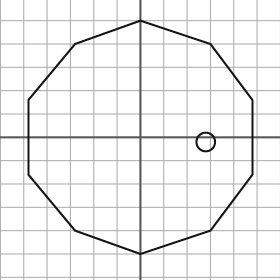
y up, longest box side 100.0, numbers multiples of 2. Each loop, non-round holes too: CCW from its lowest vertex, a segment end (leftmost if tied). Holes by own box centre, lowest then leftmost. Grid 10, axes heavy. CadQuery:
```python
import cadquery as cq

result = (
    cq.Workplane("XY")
    .moveTo(0.0, -50.0)
    .lineTo(30.0, -40.0)
    .lineTo(48.0, -16.0)
    .lineTo(48.0, 16.0)
    .lineTo(30.0, 40.0)
    .lineTo(0.0, 50.0)
    .lineTo(-28.0, 40.0)
    .lineTo(-48.0, 16.0)
    .lineTo(-48.0, -16.0)
    .lineTo(-28.0, -40.0)
    .close()
    .moveTo(28.0, -2.0)
    .circle(4.0)
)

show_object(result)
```